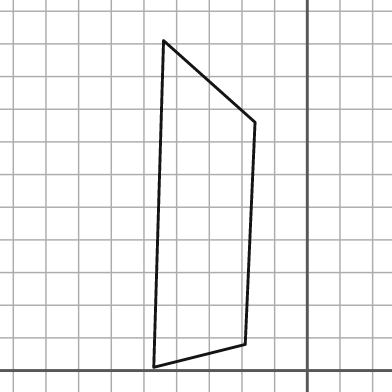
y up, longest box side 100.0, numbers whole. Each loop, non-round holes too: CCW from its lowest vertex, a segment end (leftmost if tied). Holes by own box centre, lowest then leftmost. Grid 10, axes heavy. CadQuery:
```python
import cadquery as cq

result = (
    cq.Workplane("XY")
    .moveTo(-47.0, 1.0)
    .lineTo(-19.0, 8.0)
    .lineTo(-16.0, 76.0)
    .lineTo(-44.0, 101.0)
    .close()
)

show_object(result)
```